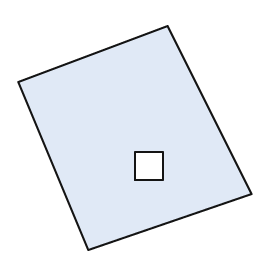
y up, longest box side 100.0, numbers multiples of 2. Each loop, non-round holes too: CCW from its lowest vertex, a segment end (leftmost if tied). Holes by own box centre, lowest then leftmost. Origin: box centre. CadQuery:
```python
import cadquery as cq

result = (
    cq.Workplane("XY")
    .moveTo(-20.0, -48.0)
    .lineTo(50.0, -24.0)
    .lineTo(14.0, 48.0)
    .lineTo(-50.0, 24.0)
    .close()
    .moveTo(0.0, -18.0)
    .lineTo(12.0, -18.0)
    .lineTo(12.0, -6.0)
    .lineTo(0.0, -6.0)
    .close()
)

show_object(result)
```